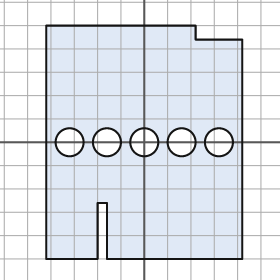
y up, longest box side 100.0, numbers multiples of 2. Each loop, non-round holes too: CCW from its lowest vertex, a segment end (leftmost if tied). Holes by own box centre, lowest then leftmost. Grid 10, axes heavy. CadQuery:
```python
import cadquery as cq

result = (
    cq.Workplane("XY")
    .moveTo(-42.0, -50.0)
    .lineTo(-20.0, -50.0)
    .lineTo(-20.0, -26.0)
    .lineTo(-16.0, -26.0)
    .lineTo(-16.0, -50.0)
    .lineTo(42.0, -50.0)
    .lineTo(42.0, 44.0)
    .lineTo(22.0, 44.0)
    .lineTo(22.0, 50.0)
    .lineTo(-42.0, 50.0)
    .close()
    .moveTo(-32.0, 0.0)
    .circle(6.0)
    .moveTo(-16.0, 0.0)
    .circle(6.0)
    .moveTo(0.0, 0.0)
    .circle(6.0)
    .moveTo(16.0, 0.0)
    .circle(6.0)
    .moveTo(32.0, 0.0)
    .circle(6.0)
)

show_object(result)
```